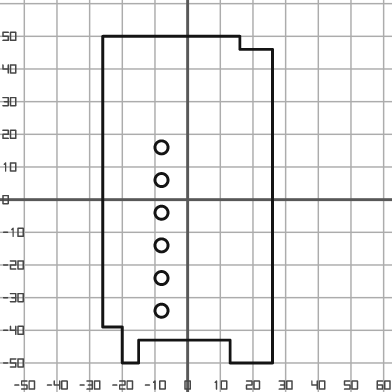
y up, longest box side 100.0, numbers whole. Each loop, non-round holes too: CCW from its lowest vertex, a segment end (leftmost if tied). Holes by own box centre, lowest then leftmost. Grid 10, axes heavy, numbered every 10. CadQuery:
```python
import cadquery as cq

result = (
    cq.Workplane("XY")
    .moveTo(-20.0, -50.0)
    .lineTo(-15.0, -50.0)
    .lineTo(-15.0, -43.0)
    .lineTo(13.0, -43.0)
    .lineTo(13.0, -50.0)
    .lineTo(26.0, -50.0)
    .lineTo(26.0, 46.0)
    .lineTo(16.0, 46.0)
    .lineTo(16.0, 50.0)
    .lineTo(-26.0, 50.0)
    .lineTo(-26.0, -39.0)
    .lineTo(-20.0, -39.0)
    .close()
    .moveTo(-8.0, -34.0)
    .circle(2.0)
    .moveTo(-8.0, -24.0)
    .circle(2.0)
    .moveTo(-8.0, -14.0)
    .circle(2.0)
    .moveTo(-8.0, -4.0)
    .circle(2.0)
    .moveTo(-8.0, 6.0)
    .circle(2.0)
    .moveTo(-8.0, 16.0)
    .circle(2.0)
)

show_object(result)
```